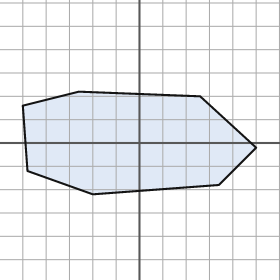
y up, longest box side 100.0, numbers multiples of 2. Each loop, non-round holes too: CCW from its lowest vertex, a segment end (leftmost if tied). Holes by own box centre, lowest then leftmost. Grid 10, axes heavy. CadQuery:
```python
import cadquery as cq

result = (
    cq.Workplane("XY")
    .moveTo(-20.0, -22.0)
    .lineTo(34.0, -18.0)
    .lineTo(50.0, -2.0)
    .lineTo(26.0, 20.0)
    .lineTo(-26.0, 22.0)
    .lineTo(-50.0, 16.0)
    .lineTo(-48.0, -12.0)
    .close()
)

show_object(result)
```